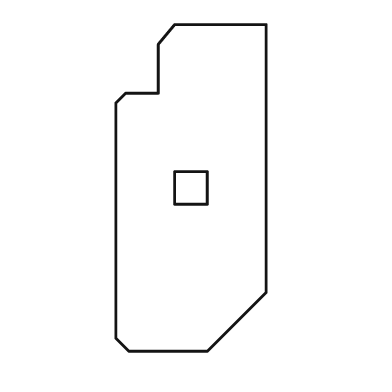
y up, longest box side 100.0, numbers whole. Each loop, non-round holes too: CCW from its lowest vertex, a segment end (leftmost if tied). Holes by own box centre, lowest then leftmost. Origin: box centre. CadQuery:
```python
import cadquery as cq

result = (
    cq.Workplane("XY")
    .moveTo(-19.0, -50.0)
    .lineTo(5.0, -50.0)
    .lineTo(23.0, -32.0)
    .lineTo(23.0, 50.0)
    .lineTo(-5.0, 50.0)
    .lineTo(-10.0, 44.0)
    .lineTo(-10.0, 29.0)
    .lineTo(-20.0, 29.0)
    .lineTo(-23.0, 26.0)
    .lineTo(-23.0, -46.0)
    .close()
    .moveTo(-5.0, -5.0)
    .lineTo(5.0, -5.0)
    .lineTo(5.0, 5.0)
    .lineTo(-5.0, 5.0)
    .close()
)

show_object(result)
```